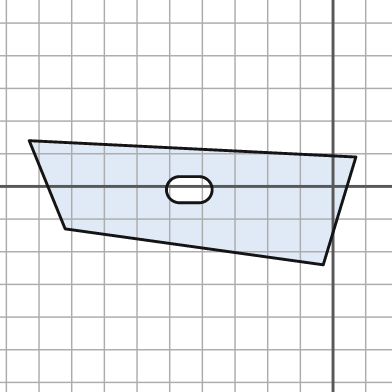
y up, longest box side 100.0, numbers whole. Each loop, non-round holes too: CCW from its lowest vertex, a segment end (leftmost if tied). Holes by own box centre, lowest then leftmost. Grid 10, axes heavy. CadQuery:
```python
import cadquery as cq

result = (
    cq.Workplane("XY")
    .moveTo(-3.0, -24.0)
    .lineTo(7.0, 9.0)
    .lineTo(-93.0, 14.0)
    .lineTo(-82.0, -13.0)
    .close()
    .moveTo(-47.0, -5.0)
    .lineTo(-41.0, -5.0)
    .threePointArc((-37.0, -1.0), (-41.0, 3.0))
    .lineTo(-47.0, 3.0)
    .threePointArc((-51.0, -1.0), (-47.0, -5.0))
    .close()
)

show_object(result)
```